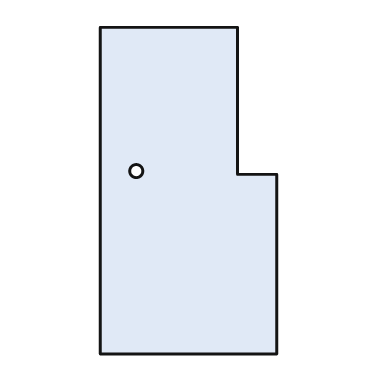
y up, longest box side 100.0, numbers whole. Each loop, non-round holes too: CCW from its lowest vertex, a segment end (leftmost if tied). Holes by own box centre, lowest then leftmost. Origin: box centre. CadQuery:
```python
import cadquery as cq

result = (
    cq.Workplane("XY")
    .moveTo(-27.0, -50.0)
    .lineTo(27.0, -50.0)
    .lineTo(27.0, 5.0)
    .lineTo(15.0, 5.0)
    .lineTo(15.0, 50.0)
    .lineTo(-27.0, 50.0)
    .close()
    .moveTo(-16.0, 6.0)
    .circle(2.0)
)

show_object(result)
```